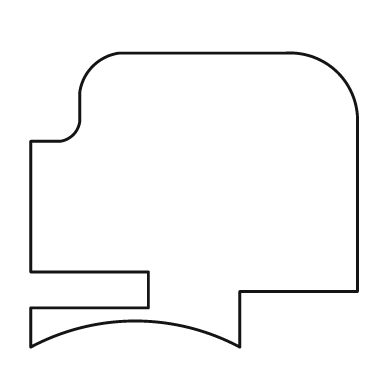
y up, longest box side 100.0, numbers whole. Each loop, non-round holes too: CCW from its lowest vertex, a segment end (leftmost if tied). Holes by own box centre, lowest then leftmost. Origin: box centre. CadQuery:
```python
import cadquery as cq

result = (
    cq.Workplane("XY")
    .moveTo(-50.0, -45.0)
    .threePointArc((-18.0, -37.0), (14.0, -45.0))
    .lineTo(14.0, -28.0)
    .lineTo(50.0, -28.0)
    .lineTo(50.0, 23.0)
    .threePointArc((44.0, 39.0), (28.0, 45.0))
    .lineTo(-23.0, 45.0)
    .threePointArc((-31.0, 41.0), (-35.0, 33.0))
    .lineTo(-35.0, 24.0)
    .threePointArc((-37.0, 20.0), (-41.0, 18.0))
    .lineTo(-50.0, 18.0)
    .lineTo(-50.0, -22.0)
    .lineTo(-14.0, -22.0)
    .lineTo(-14.0, -33.0)
    .lineTo(-50.0, -33.0)
    .close()
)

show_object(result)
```